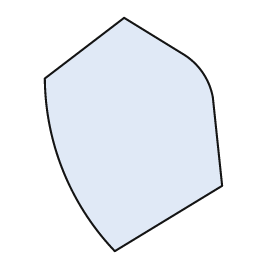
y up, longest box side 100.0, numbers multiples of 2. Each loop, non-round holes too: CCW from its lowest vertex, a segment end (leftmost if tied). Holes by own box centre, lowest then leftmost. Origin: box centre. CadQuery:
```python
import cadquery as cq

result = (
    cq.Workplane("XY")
    .moveTo(-8.0, -50.0)
    .lineTo(38.0, -22.0)
    .lineTo(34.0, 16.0)
    .threePointArc((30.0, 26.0), (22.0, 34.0))
    .lineTo(-4.0, 50.0)
    .lineTo(-38.0, 24.0)
    .threePointArc((-30.0, -16.0), (-8.0, -50.0))
    .close()
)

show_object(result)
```